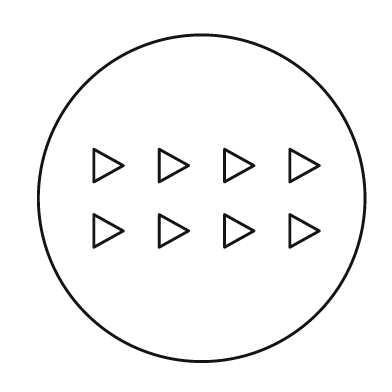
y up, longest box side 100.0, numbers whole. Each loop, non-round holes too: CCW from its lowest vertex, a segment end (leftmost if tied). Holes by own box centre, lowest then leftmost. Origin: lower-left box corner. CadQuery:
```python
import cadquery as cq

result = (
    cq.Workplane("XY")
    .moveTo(50.0, 50.0)
    .circle(50.0)
    .moveTo(17.0, 35.0)
    .lineTo(26.0, 40.0)
    .lineTo(17.0, 45.0)
    .close()
    .moveTo(37.0, 35.0)
    .lineTo(46.0, 40.0)
    .lineTo(37.0, 45.0)
    .close()
    .moveTo(57.0, 35.0)
    .lineTo(66.0, 40.0)
    .lineTo(57.0, 45.0)
    .close()
    .moveTo(77.0, 35.0)
    .lineTo(86.0, 40.0)
    .lineTo(77.0, 45.0)
    .close()
    .moveTo(17.0, 55.0)
    .lineTo(26.0, 60.0)
    .lineTo(17.0, 65.0)
    .close()
    .moveTo(37.0, 55.0)
    .lineTo(46.0, 60.0)
    .lineTo(37.0, 65.0)
    .close()
    .moveTo(57.0, 55.0)
    .lineTo(66.0, 60.0)
    .lineTo(57.0, 65.0)
    .close()
    .moveTo(77.0, 55.0)
    .lineTo(86.0, 60.0)
    .lineTo(77.0, 65.0)
    .close()
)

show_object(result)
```